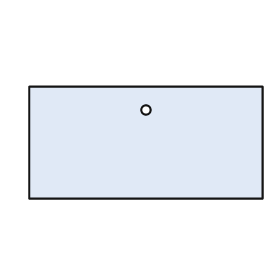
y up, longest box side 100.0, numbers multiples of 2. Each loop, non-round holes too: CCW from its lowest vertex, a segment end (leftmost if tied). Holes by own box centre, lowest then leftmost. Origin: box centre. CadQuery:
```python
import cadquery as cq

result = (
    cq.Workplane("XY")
    .moveTo(-50.0, -24.0)
    .lineTo(50.0, -24.0)
    .lineTo(50.0, 24.0)
    .lineTo(-50.0, 24.0)
    .close()
    .moveTo(0.0, 14.0)
    .circle(2.0)
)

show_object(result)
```